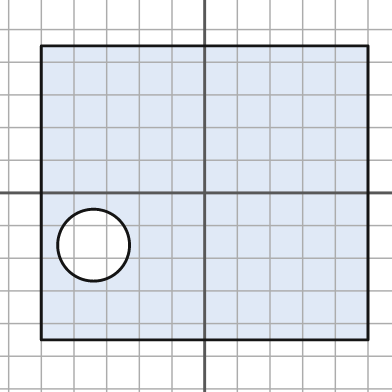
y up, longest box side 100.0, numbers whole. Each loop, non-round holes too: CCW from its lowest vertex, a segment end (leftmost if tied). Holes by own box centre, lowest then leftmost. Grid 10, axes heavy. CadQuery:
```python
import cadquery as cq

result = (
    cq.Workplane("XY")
    .moveTo(-50.0, -45.0)
    .lineTo(50.0, -45.0)
    .lineTo(50.0, 45.0)
    .lineTo(-50.0, 45.0)
    .close()
    .moveTo(-34.0, -16.0)
    .circle(11.0)
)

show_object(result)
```